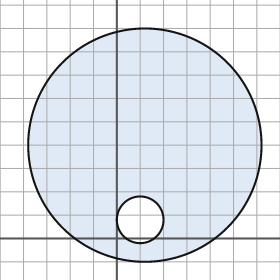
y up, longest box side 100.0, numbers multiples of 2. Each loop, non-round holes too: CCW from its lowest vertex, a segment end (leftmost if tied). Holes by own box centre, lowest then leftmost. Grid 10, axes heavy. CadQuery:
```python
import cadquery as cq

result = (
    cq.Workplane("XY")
    .moveTo(12.0, 40.0)
    .circle(50.0)
    .moveTo(10.0, 8.0)
    .circle(10.0)
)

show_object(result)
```